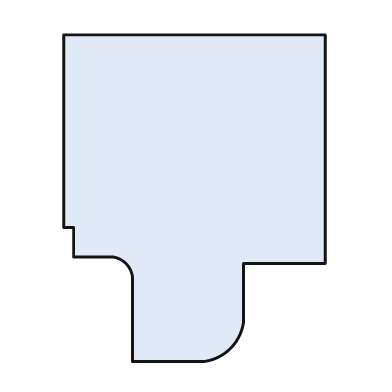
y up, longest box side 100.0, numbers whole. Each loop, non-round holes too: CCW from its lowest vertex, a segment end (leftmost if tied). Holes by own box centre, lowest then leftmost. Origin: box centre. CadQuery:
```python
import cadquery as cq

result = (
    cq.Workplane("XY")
    .moveTo(-19.0, -50.0)
    .lineTo(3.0, -50.0)
    .threePointArc((11.0, -46.0), (15.0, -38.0))
    .lineTo(15.0, -20.0)
    .lineTo(40.0, -20.0)
    .lineTo(40.0, 50.0)
    .lineTo(-40.0, 50.0)
    .lineTo(-40.0, -9.0)
    .lineTo(-37.0, -9.0)
    .lineTo(-37.0, -18.0)
    .lineTo(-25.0, -18.0)
    .threePointArc((-21.0, -20.0), (-19.0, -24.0))
    .close()
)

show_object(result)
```